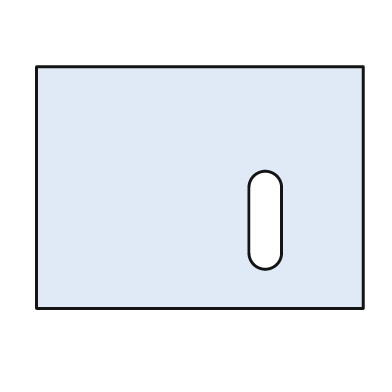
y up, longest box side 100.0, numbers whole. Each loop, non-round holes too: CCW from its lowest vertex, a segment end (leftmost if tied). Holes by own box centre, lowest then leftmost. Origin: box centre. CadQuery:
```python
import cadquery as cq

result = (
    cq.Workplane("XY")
    .moveTo(-50.0, -37.0)
    .lineTo(50.0, -37.0)
    .lineTo(50.0, 37.0)
    .lineTo(-50.0, 37.0)
    .close()
    .moveTo(15.0, -20.0)
    .threePointArc((20.0, -25.0), (25.0, -20.0))
    .lineTo(25.0, 0.0)
    .threePointArc((20.0, 5.0), (15.0, 0.0))
    .close()
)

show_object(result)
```